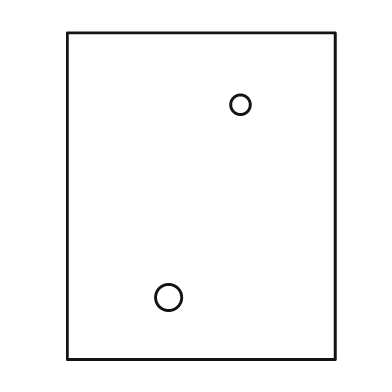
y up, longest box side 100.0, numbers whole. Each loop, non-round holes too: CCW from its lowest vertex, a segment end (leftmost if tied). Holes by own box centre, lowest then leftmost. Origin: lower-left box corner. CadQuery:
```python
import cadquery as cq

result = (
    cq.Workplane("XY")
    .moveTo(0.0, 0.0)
    .lineTo(82.0, 0.0)
    .lineTo(82.0, 100.0)
    .lineTo(0.0, 100.0)
    .close()
    .moveTo(31.0, 19.0)
    .circle(4.0)
    .moveTo(53.0, 78.0)
    .circle(3.0)
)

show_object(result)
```